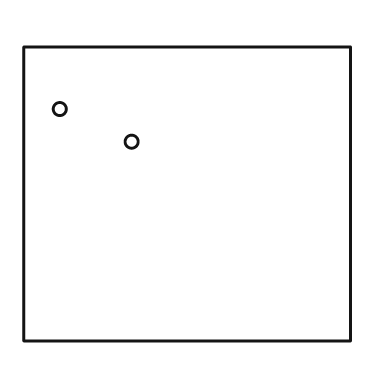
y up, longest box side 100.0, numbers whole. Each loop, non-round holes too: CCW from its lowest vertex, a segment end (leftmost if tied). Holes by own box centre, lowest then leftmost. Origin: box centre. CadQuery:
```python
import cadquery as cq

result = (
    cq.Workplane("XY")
    .moveTo(-50.0, -45.0)
    .lineTo(50.0, -45.0)
    .lineTo(50.0, 45.0)
    .lineTo(-50.0, 45.0)
    .close()
    .moveTo(-17.0, 16.0)
    .circle(2.0)
    .moveTo(-39.0, 26.0)
    .circle(2.0)
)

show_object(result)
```